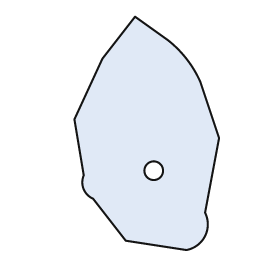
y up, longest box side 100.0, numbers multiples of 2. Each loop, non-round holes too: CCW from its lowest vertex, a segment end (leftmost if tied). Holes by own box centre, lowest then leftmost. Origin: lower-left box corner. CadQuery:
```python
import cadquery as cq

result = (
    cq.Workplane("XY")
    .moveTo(48.0, 0.0)
    .threePointArc((56.0, 6.0), (56.0, 16.0))
    .lineTo(62.0, 48.0)
    .lineTo(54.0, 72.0)
    .threePointArc((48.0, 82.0), (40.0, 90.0))
    .lineTo(26.0, 100.0)
    .lineTo(12.0, 82.0)
    .lineTo(0.0, 56.0)
    .lineTo(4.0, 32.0)
    .threePointArc((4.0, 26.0), (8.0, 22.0))
    .lineTo(22.0, 4.0)
    .close()
    .moveTo(34.0, 34.0)
    .circle(4.0)
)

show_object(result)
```